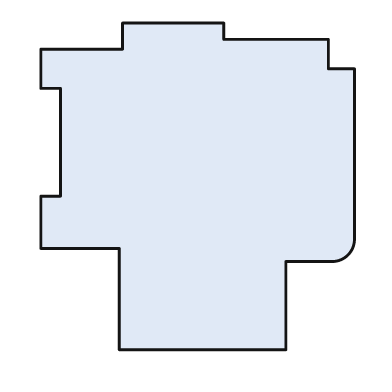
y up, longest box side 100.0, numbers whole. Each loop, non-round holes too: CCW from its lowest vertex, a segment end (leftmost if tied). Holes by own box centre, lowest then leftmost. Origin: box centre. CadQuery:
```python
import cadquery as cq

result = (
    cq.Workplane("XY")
    .moveTo(-24.0, -50.0)
    .lineTo(27.0, -50.0)
    .lineTo(27.0, -23.0)
    .lineTo(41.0, -23.0)
    .threePointArc((46.0, -21.0), (48.0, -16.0))
    .lineTo(48.0, 36.0)
    .lineTo(40.0, 36.0)
    .lineTo(40.0, 45.0)
    .lineTo(8.0, 45.0)
    .lineTo(8.0, 50.0)
    .lineTo(-23.0, 50.0)
    .lineTo(-23.0, 42.0)
    .lineTo(-48.0, 42.0)
    .lineTo(-48.0, 30.0)
    .lineTo(-42.0, 30.0)
    .lineTo(-42.0, -3.0)
    .lineTo(-48.0, -3.0)
    .lineTo(-48.0, -19.0)
    .lineTo(-24.0, -19.0)
    .close()
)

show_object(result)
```